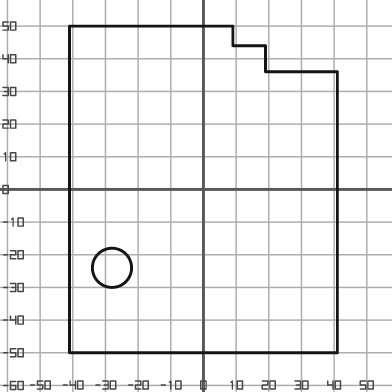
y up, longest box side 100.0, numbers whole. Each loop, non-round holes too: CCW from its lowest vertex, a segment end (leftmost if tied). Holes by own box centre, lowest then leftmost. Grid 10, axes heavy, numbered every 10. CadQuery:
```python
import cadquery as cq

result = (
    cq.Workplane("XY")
    .moveTo(-41.0, -50.0)
    .lineTo(41.0, -50.0)
    .lineTo(41.0, 36.0)
    .lineTo(19.0, 36.0)
    .lineTo(19.0, 44.0)
    .lineTo(9.0, 44.0)
    .lineTo(9.0, 50.0)
    .lineTo(-41.0, 50.0)
    .close()
    .moveTo(-28.0, -24.0)
    .circle(6.0)
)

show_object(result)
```